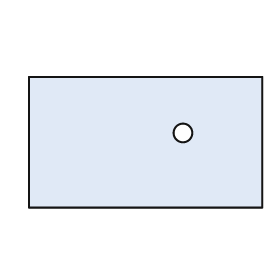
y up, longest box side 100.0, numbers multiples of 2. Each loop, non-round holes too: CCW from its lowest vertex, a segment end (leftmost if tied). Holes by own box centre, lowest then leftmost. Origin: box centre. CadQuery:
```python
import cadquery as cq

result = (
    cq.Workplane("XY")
    .moveTo(-50.0, -28.0)
    .lineTo(50.0, -28.0)
    .lineTo(50.0, 28.0)
    .lineTo(-50.0, 28.0)
    .close()
    .moveTo(16.0, 4.0)
    .circle(4.0)
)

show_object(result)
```